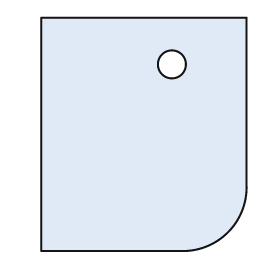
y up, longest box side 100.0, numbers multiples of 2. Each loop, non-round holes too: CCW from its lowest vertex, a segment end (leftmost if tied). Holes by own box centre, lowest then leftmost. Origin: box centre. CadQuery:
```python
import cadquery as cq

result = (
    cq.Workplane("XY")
    .moveTo(-44.0, -50.0)
    .lineTo(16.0, -50.0)
    .threePointArc((36.0, -42.0), (44.0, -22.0))
    .lineTo(44.0, 50.0)
    .lineTo(-44.0, 50.0)
    .close()
    .moveTo(12.0, 30.0)
    .circle(6.0)
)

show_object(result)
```